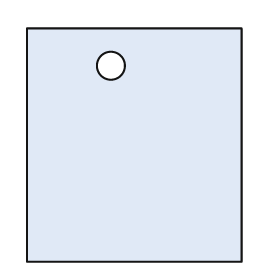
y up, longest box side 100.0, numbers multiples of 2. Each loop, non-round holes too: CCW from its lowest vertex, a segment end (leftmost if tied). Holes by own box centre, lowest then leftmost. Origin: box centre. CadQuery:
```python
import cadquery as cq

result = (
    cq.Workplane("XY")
    .moveTo(-46.0, -50.0)
    .lineTo(46.0, -50.0)
    .lineTo(46.0, 50.0)
    .lineTo(-46.0, 50.0)
    .close()
    .moveTo(-10.0, 34.0)
    .circle(6.0)
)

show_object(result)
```